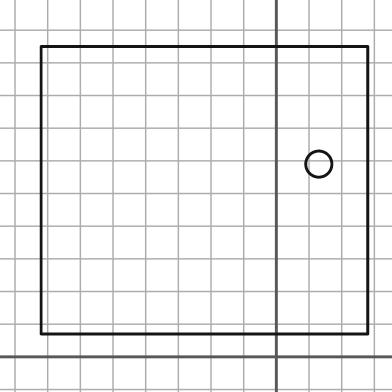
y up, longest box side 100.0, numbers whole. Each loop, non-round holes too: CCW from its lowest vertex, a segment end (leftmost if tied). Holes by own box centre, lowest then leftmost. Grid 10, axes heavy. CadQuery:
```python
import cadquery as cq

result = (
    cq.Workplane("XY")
    .moveTo(-72.0, 7.0)
    .lineTo(28.0, 7.0)
    .lineTo(28.0, 95.0)
    .lineTo(-72.0, 95.0)
    .close()
    .moveTo(13.0, 59.0)
    .circle(4.0)
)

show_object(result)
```